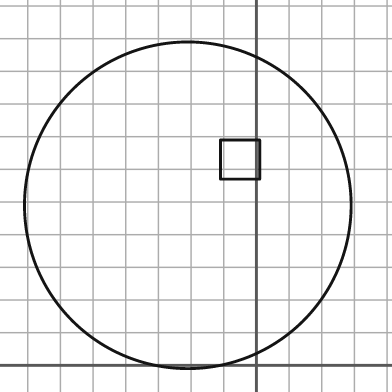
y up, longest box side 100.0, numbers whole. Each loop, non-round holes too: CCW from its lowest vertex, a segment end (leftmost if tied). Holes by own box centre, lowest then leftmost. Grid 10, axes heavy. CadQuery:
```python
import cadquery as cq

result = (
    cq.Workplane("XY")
    .moveTo(-21.0, 49.0)
    .circle(50.0)
    .moveTo(-11.0, 57.0)
    .lineTo(1.0, 57.0)
    .lineTo(1.0, 69.0)
    .lineTo(-11.0, 69.0)
    .close()
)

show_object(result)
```